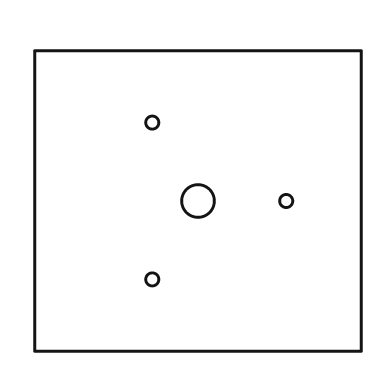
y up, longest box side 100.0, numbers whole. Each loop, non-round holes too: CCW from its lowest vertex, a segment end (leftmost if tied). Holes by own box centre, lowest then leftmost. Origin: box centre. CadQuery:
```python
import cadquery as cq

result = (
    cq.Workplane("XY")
    .moveTo(-50.0, -46.0)
    .lineTo(50.0, -46.0)
    .lineTo(50.0, 46.0)
    .lineTo(-50.0, 46.0)
    .close()
    .moveTo(-14.0, -24.0)
    .circle(2.0)
    .moveTo(0.0, 0.0)
    .circle(5.0)
    .moveTo(27.0, 0.0)
    .circle(2.0)
    .moveTo(-14.0, 24.0)
    .circle(2.0)
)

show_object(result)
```